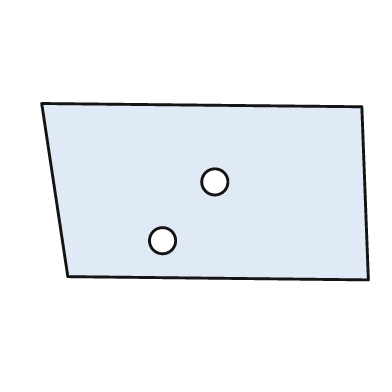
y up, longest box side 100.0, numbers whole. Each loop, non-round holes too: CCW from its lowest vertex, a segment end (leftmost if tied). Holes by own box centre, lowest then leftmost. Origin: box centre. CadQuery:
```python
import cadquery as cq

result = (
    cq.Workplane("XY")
    .moveTo(50.0, -27.0)
    .lineTo(48.0, 26.0)
    .lineTo(-50.0, 27.0)
    .lineTo(-42.0, -26.0)
    .close()
    .moveTo(-13.0, -15.0)
    .circle(4.0)
    .moveTo(3.0, 3.0)
    .circle(4.0)
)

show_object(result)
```